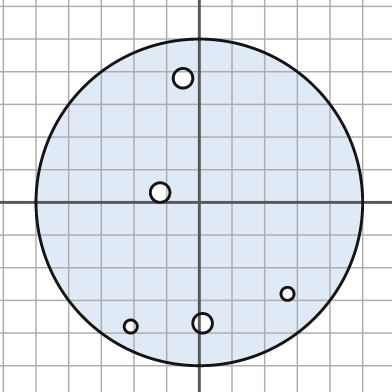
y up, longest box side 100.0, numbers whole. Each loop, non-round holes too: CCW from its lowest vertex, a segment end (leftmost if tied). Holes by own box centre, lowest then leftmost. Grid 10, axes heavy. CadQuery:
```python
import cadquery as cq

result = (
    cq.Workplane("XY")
    .moveTo(0.0, 0.0)
    .circle(50.0)
    .moveTo(-21.0, -38.0)
    .circle(2.0)
    .moveTo(1.0, -37.0)
    .circle(3.0)
    .moveTo(27.0, -28.0)
    .circle(2.0)
    .moveTo(-12.0, 3.0)
    .circle(3.0)
    .moveTo(-5.0, 38.0)
    .circle(3.0)
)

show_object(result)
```